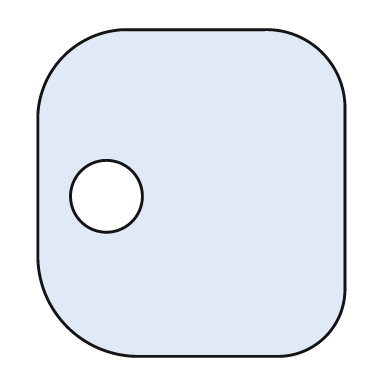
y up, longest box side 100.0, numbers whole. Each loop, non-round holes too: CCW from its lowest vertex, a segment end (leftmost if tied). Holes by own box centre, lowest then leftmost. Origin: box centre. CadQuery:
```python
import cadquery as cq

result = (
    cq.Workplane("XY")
    .moveTo(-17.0, -50.0)
    .lineTo(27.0, -50.0)
    .threePointArc((41.0, -44.0), (47.0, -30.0))
    .lineTo(47.0, 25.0)
    .threePointArc((40.0, 43.0), (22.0, 50.0))
    .lineTo(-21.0, 50.0)
    .threePointArc((-39.0, 42.0), (-47.0, 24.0))
    .lineTo(-47.0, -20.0)
    .threePointArc((-38.0, -41.0), (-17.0, -50.0))
    .close()
    .moveTo(-26.0, -1.0)
    .circle(11.0)
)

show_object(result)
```